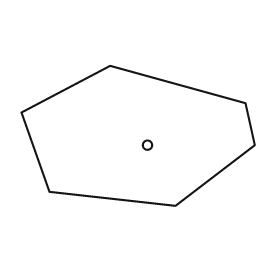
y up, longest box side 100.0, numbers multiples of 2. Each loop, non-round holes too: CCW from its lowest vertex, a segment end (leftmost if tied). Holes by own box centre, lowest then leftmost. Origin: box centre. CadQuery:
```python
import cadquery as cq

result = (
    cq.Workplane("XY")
    .moveTo(16.0, -30.0)
    .lineTo(50.0, -4.0)
    .lineTo(46.0, 14.0)
    .lineTo(-12.0, 30.0)
    .lineTo(-50.0, 10.0)
    .lineTo(-38.0, -24.0)
    .close()
    .moveTo(4.0, -4.0)
    .circle(2.0)
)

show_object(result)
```